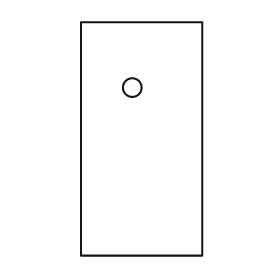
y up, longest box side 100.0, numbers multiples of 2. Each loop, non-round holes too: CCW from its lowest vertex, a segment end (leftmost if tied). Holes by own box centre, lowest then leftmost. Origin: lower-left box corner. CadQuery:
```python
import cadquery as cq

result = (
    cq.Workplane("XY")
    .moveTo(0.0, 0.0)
    .lineTo(52.0, 0.0)
    .lineTo(52.0, 100.0)
    .lineTo(0.0, 100.0)
    .close()
    .moveTo(22.0, 72.0)
    .circle(4.0)
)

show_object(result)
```